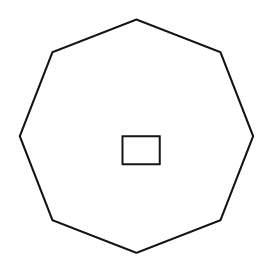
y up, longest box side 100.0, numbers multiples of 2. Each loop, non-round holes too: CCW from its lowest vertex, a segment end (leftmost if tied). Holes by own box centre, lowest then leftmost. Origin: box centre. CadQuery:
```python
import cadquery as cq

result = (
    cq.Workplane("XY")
    .moveTo(0.0, -50.0)
    .lineTo(36.0, -36.0)
    .lineTo(50.0, 0.0)
    .lineTo(36.0, 36.0)
    .lineTo(0.0, 50.0)
    .lineTo(-36.0, 36.0)
    .lineTo(-50.0, 0.0)
    .lineTo(-36.0, -36.0)
    .close()
    .moveTo(-6.0, -12.0)
    .lineTo(10.0, -12.0)
    .lineTo(10.0, 0.0)
    .lineTo(-6.0, 0.0)
    .close()
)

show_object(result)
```